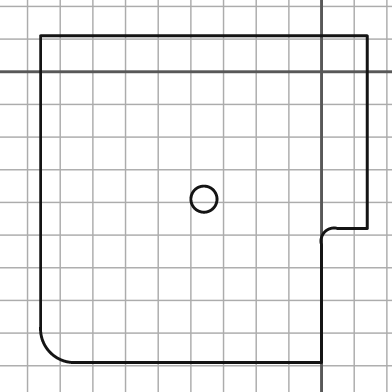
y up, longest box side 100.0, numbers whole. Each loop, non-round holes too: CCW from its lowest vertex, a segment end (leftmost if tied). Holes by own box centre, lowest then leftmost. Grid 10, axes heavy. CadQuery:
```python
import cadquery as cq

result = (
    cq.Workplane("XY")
    .moveTo(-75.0, -89.0)
    .lineTo(0.0, -89.0)
    .lineTo(0.0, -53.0)
    .threePointArc((1.0, -49.0), (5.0, -48.0))
    .lineTo(14.0, -48.0)
    .lineTo(14.0, 11.0)
    .lineTo(-86.0, 11.0)
    .lineTo(-86.0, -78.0)
    .threePointArc((-83.0, -86.0), (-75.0, -89.0))
    .close()
    .moveTo(-36.0, -39.0)
    .circle(4.0)
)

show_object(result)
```